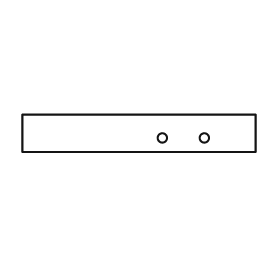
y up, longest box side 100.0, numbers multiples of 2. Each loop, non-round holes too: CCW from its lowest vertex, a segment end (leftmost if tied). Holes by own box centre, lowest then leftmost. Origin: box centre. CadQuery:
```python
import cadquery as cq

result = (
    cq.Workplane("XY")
    .moveTo(-50.0, -8.0)
    .lineTo(50.0, -8.0)
    .lineTo(50.0, 8.0)
    .lineTo(-50.0, 8.0)
    .close()
    .moveTo(10.0, -2.0)
    .circle(2.0)
    .moveTo(28.0, -2.0)
    .circle(2.0)
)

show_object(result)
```